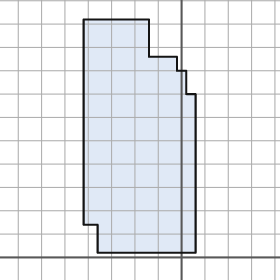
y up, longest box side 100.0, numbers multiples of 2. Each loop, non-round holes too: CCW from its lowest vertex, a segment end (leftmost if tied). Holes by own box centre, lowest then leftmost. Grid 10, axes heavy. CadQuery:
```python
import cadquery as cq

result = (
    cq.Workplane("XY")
    .moveTo(-36.0, 2.0)
    .lineTo(6.0, 2.0)
    .lineTo(6.0, 70.0)
    .lineTo(2.0, 70.0)
    .lineTo(2.0, 80.0)
    .lineTo(-2.0, 80.0)
    .lineTo(-2.0, 86.0)
    .lineTo(-14.0, 86.0)
    .lineTo(-14.0, 102.0)
    .lineTo(-42.0, 102.0)
    .lineTo(-42.0, 14.0)
    .lineTo(-36.0, 14.0)
    .close()
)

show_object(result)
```